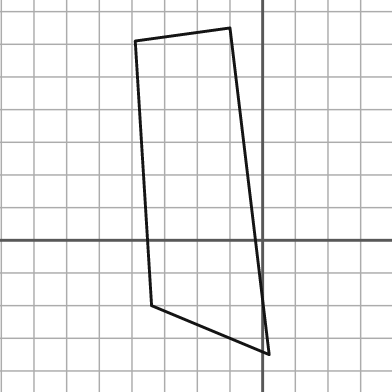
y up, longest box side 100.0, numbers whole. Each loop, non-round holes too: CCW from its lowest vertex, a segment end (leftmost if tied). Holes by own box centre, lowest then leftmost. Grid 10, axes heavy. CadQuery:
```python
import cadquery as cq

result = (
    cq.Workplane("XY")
    .moveTo(2.0, -35.0)
    .lineTo(-10.0, 65.0)
    .lineTo(-39.0, 61.0)
    .lineTo(-34.0, -20.0)
    .close()
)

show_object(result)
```